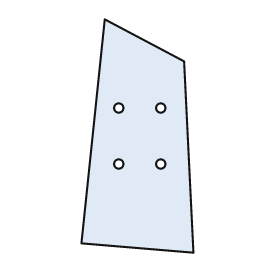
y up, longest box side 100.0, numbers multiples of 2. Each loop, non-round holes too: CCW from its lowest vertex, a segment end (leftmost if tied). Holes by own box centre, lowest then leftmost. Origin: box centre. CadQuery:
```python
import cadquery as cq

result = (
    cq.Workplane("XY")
    .moveTo(24.0, -50.0)
    .lineTo(20.0, 32.0)
    .lineTo(-14.0, 50.0)
    .lineTo(-24.0, -46.0)
    .close()
    .moveTo(-8.0, -12.0)
    .circle(2.0)
    .moveTo(10.0, -12.0)
    .circle(2.0)
    .moveTo(-8.0, 12.0)
    .circle(2.0)
    .moveTo(10.0, 12.0)
    .circle(2.0)
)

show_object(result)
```